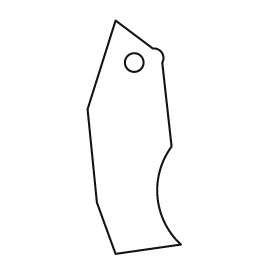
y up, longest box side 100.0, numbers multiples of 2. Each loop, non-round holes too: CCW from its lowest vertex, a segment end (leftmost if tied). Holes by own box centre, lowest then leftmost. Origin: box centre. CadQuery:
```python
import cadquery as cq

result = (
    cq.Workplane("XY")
    .moveTo(-8.0, -50.0)
    .lineTo(20.0, -46.0)
    .threePointArc((10.0, -26.0), (16.0, -4.0))
    .lineTo(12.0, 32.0)
    .threePointArc((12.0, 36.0), (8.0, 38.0))
    .lineTo(-8.0, 50.0)
    .lineTo(-20.0, 12.0)
    .lineTo(-16.0, -28.0)
    .close()
    .moveTo(0.0, 32.0)
    .circle(4.0)
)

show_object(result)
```